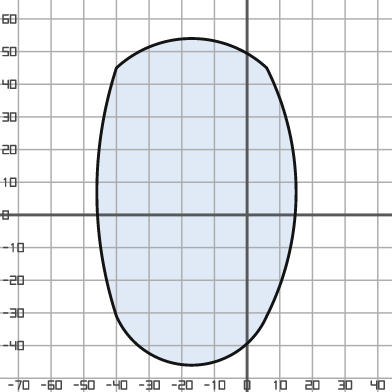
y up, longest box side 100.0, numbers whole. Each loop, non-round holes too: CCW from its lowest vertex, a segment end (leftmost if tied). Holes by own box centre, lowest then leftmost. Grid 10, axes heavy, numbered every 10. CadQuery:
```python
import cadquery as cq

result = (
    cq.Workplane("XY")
    .moveTo(-40.0, -31.0)
    .threePointArc((-17.0, -46.0), (6.0, -31.0))
    .threePointArc((15.0, 7.0), (6.0, 45.0))
    .threePointArc((-17.0, 54.0), (-40.0, 45.0))
    .threePointArc((-46.0, 7.0), (-40.0, -31.0))
    .close()
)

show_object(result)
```